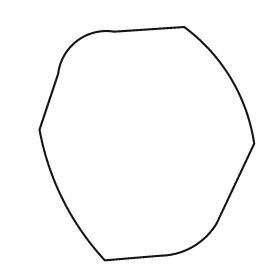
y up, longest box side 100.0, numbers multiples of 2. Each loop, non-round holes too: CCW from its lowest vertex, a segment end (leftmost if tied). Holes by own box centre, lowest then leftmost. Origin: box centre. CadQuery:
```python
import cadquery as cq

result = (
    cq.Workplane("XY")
    .moveTo(-18.0, -50.0)
    .lineTo(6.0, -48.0)
    .threePointArc((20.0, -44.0), (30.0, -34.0))
    .lineTo(46.0, 0.0)
    .threePointArc((36.0, 28.0), (16.0, 50.0))
    .lineTo(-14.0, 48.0)
    .threePointArc((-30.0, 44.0), (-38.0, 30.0))
    .lineTo(-46.0, 6.0)
    .threePointArc((-36.0, -24.0), (-18.0, -50.0))
    .close()
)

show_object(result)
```